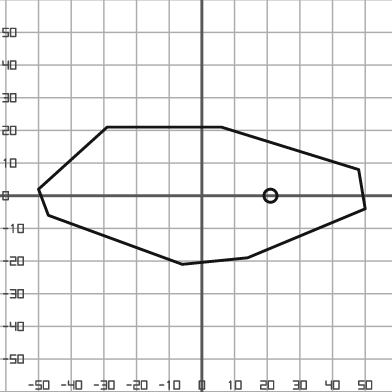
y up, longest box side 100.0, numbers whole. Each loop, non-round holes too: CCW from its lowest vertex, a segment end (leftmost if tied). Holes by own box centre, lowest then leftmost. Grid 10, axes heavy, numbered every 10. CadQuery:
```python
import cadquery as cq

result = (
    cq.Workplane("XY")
    .moveTo(-6.0, -21.0)
    .lineTo(14.0, -19.0)
    .lineTo(50.0, -4.0)
    .lineTo(48.0, 8.0)
    .lineTo(6.0, 21.0)
    .lineTo(-29.0, 21.0)
    .lineTo(-50.0, 2.0)
    .lineTo(-47.0, -6.0)
    .close()
    .moveTo(21.0, 0.0)
    .circle(2.0)
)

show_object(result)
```